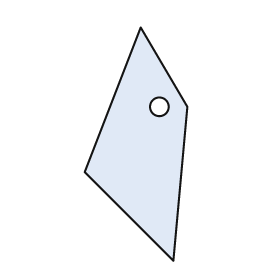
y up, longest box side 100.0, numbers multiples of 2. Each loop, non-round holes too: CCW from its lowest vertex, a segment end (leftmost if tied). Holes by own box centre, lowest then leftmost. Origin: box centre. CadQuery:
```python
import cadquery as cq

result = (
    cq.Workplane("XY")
    .moveTo(16.0, -50.0)
    .lineTo(22.0, 16.0)
    .lineTo(2.0, 50.0)
    .lineTo(-22.0, -12.0)
    .close()
    .moveTo(10.0, 16.0)
    .circle(4.0)
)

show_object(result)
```